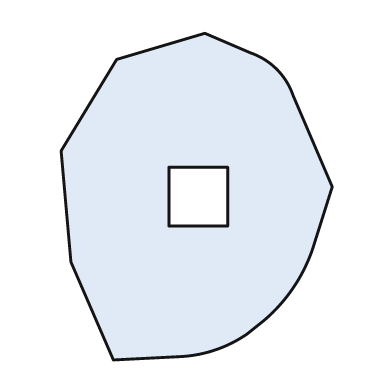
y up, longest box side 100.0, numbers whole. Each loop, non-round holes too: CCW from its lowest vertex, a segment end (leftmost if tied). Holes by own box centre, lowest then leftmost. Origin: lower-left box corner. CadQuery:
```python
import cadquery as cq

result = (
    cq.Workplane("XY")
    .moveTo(16.0, 0.0)
    .lineTo(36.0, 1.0)
    .threePointArc((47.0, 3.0), (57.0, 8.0))
    .lineTo(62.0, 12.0)
    .threePointArc((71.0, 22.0), (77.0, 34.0))
    .lineTo(83.0, 53.0)
    .lineTo(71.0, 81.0)
    .threePointArc((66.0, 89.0), (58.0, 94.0))
    .lineTo(44.0, 100.0)
    .lineTo(17.0, 92.0)
    .lineTo(0.0, 64.0)
    .lineTo(3.0, 30.0)
    .close()
    .moveTo(33.0, 41.0)
    .lineTo(51.0, 41.0)
    .lineTo(51.0, 59.0)
    .lineTo(33.0, 59.0)
    .close()
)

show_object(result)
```